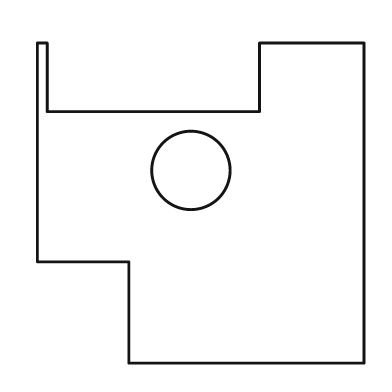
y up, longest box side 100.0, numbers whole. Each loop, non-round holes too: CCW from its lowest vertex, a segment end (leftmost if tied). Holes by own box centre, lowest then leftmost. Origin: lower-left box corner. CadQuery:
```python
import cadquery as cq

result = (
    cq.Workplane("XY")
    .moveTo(28.0, 0.0)
    .lineTo(100.0, 0.0)
    .lineTo(100.0, 98.0)
    .lineTo(68.0, 98.0)
    .lineTo(68.0, 77.0)
    .lineTo(3.0, 77.0)
    .lineTo(3.0, 98.0)
    .lineTo(0.0, 98.0)
    .lineTo(0.0, 31.0)
    .lineTo(28.0, 31.0)
    .close()
    .moveTo(47.0, 59.0)
    .circle(12.0)
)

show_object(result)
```